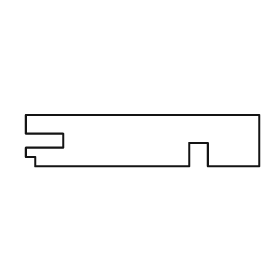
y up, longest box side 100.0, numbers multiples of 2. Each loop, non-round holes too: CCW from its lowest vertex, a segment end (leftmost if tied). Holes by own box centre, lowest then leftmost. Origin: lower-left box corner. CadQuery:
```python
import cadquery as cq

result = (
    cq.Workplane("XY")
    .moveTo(4.0, 0.0)
    .lineTo(70.0, 0.0)
    .lineTo(70.0, 10.0)
    .lineTo(78.0, 10.0)
    .lineTo(78.0, 0.0)
    .lineTo(100.0, 0.0)
    .lineTo(100.0, 22.0)
    .lineTo(0.0, 22.0)
    .lineTo(0.0, 14.0)
    .lineTo(16.0, 14.0)
    .lineTo(16.0, 8.0)
    .lineTo(0.0, 8.0)
    .lineTo(0.0, 4.0)
    .lineTo(4.0, 4.0)
    .close()
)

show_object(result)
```